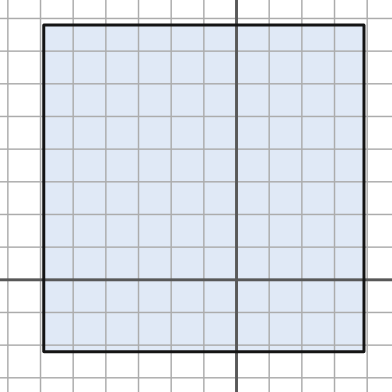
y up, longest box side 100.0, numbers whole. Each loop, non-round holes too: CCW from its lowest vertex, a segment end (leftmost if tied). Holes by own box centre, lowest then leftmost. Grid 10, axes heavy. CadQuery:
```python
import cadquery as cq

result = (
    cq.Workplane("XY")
    .moveTo(-59.0, -22.0)
    .lineTo(39.0, -22.0)
    .lineTo(39.0, 78.0)
    .lineTo(-59.0, 78.0)
    .close()
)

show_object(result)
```